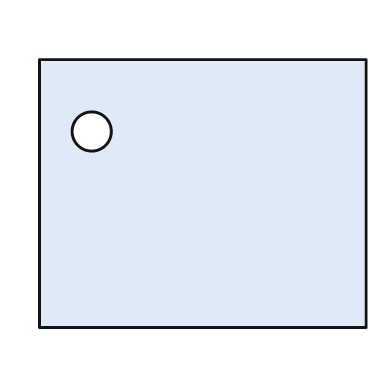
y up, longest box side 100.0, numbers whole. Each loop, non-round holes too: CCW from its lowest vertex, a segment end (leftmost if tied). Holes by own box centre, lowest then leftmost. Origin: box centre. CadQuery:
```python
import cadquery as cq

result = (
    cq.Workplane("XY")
    .moveTo(-50.0, -41.0)
    .lineTo(50.0, -41.0)
    .lineTo(50.0, 41.0)
    .lineTo(-50.0, 41.0)
    .close()
    .moveTo(-34.0, 19.0)
    .circle(6.0)
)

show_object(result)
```